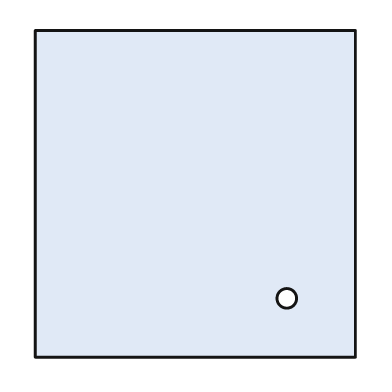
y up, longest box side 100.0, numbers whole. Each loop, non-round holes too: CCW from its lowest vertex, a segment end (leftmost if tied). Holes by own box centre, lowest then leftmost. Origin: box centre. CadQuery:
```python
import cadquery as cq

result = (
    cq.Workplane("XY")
    .moveTo(-49.0, -50.0)
    .lineTo(49.0, -50.0)
    .lineTo(49.0, 50.0)
    .lineTo(-49.0, 50.0)
    .close()
    .moveTo(28.0, -32.0)
    .circle(3.0)
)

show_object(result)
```